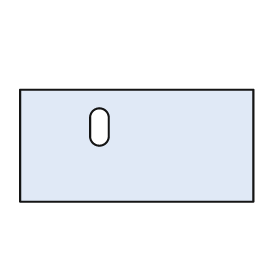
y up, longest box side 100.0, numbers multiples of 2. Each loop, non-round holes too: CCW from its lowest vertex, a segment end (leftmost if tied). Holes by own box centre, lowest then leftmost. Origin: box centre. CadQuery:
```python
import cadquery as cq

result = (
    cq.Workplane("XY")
    .moveTo(-50.0, -24.0)
    .lineTo(50.0, -24.0)
    .lineTo(50.0, 24.0)
    .lineTo(-50.0, 24.0)
    .close()
    .moveTo(-20.0, 4.0)
    .threePointArc((-16.0, 0.0), (-12.0, 4.0))
    .lineTo(-12.0, 12.0)
    .threePointArc((-16.0, 16.0), (-20.0, 12.0))
    .close()
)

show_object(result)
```